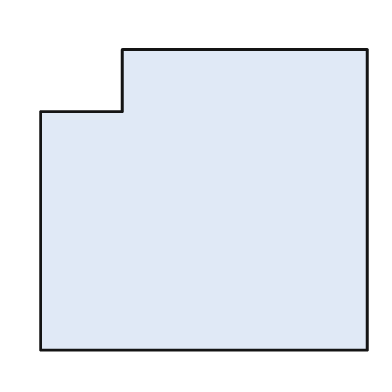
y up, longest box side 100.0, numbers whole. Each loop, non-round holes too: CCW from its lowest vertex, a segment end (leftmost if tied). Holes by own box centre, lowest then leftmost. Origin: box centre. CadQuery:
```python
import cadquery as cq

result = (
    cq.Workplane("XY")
    .moveTo(-50.0, -46.0)
    .lineTo(50.0, -46.0)
    .lineTo(50.0, 46.0)
    .lineTo(-25.0, 46.0)
    .lineTo(-25.0, 27.0)
    .lineTo(-50.0, 27.0)
    .close()
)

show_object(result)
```